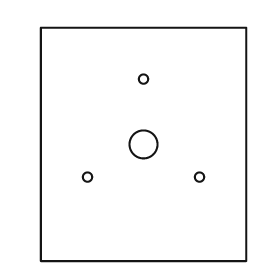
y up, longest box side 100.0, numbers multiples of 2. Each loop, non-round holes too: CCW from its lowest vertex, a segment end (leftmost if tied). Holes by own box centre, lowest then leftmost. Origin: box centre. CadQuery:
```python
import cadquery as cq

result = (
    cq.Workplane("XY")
    .moveTo(-44.0, -50.0)
    .lineTo(44.0, -50.0)
    .lineTo(44.0, 50.0)
    .lineTo(-44.0, 50.0)
    .close()
    .moveTo(-24.0, -14.0)
    .circle(2.0)
    .moveTo(24.0, -14.0)
    .circle(2.0)
    .moveTo(0.0, 0.0)
    .circle(6.0)
    .moveTo(0.0, 28.0)
    .circle(2.0)
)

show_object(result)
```